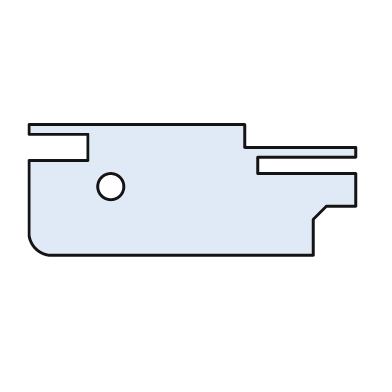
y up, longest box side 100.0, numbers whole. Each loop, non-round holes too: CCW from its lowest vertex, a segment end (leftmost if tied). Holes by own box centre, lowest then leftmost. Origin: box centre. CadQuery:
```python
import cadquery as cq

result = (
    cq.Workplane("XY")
    .moveTo(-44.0, -20.0)
    .lineTo(37.0, -20.0)
    .lineTo(37.0, -9.0)
    .lineTo(41.0, -5.0)
    .lineTo(50.0, -5.0)
    .lineTo(50.0, 5.0)
    .lineTo(20.0, 5.0)
    .lineTo(20.0, 10.0)
    .lineTo(50.0, 10.0)
    .lineTo(50.0, 13.0)
    .lineTo(16.0, 13.0)
    .lineTo(16.0, 20.0)
    .lineTo(-50.0, 20.0)
    .lineTo(-50.0, 17.0)
    .lineTo(-32.0, 17.0)
    .lineTo(-32.0, 9.0)
    .lineTo(-50.0, 9.0)
    .lineTo(-50.0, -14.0)
    .threePointArc((-48.0, -18.0), (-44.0, -20.0))
    .close()
    .moveTo(-25.0, 1.0)
    .circle(4.0)
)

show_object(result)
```